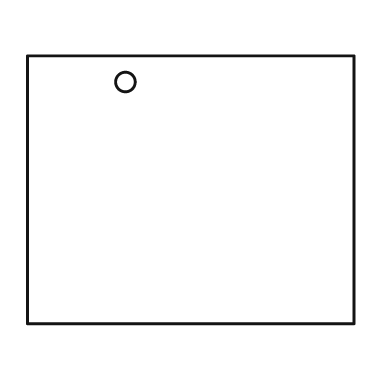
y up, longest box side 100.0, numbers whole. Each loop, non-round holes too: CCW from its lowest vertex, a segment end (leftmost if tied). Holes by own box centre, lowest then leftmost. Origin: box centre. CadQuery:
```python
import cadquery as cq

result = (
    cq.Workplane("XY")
    .moveTo(-50.0, -41.0)
    .lineTo(50.0, -41.0)
    .lineTo(50.0, 41.0)
    .lineTo(-50.0, 41.0)
    .close()
    .moveTo(-20.0, 33.0)
    .circle(3.0)
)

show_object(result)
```